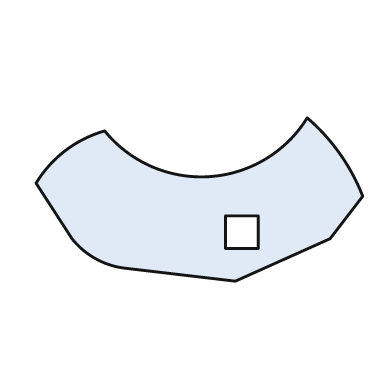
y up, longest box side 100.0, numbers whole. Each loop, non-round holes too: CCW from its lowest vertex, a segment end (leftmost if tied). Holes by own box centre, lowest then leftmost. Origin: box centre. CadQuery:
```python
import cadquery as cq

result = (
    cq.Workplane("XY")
    .moveTo(11.0, -25.0)
    .lineTo(40.0, -12.0)
    .lineTo(50.0, 1.0)
    .threePointArc((43.0, 14.0), (33.0, 25.0))
    .threePointArc((3.0, 7.0), (-29.0, 21.0))
    .threePointArc((-41.0, 15.0), (-50.0, 5.0))
    .lineTo(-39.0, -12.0)
    .threePointArc((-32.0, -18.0), (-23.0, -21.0))
    .close()
    .moveTo(8.0, -15.0)
    .lineTo(18.0, -15.0)
    .lineTo(18.0, -5.0)
    .lineTo(8.0, -5.0)
    .close()
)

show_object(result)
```